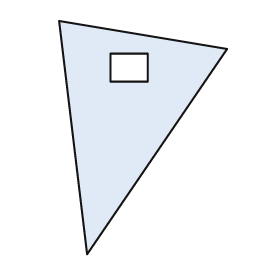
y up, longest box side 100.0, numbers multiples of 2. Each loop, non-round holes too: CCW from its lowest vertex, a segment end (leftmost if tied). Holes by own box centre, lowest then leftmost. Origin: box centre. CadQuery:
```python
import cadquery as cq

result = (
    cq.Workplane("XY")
    .moveTo(-24.0, -50.0)
    .lineTo(36.0, 38.0)
    .lineTo(-36.0, 50.0)
    .close()
    .moveTo(-14.0, 24.0)
    .lineTo(2.0, 24.0)
    .lineTo(2.0, 36.0)
    .lineTo(-14.0, 36.0)
    .close()
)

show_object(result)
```